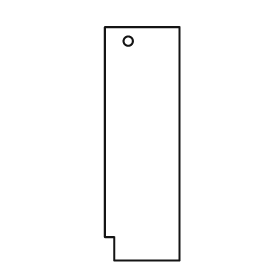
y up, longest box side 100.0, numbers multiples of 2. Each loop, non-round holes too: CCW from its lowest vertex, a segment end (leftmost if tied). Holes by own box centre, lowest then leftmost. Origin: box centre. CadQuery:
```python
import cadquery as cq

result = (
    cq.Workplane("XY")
    .moveTo(-12.0, -50.0)
    .lineTo(16.0, -50.0)
    .lineTo(16.0, 50.0)
    .lineTo(-16.0, 50.0)
    .lineTo(-16.0, -40.0)
    .lineTo(-12.0, -40.0)
    .close()
    .moveTo(-6.0, 44.0)
    .circle(2.0)
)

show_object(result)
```